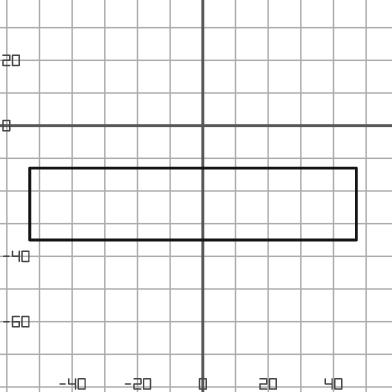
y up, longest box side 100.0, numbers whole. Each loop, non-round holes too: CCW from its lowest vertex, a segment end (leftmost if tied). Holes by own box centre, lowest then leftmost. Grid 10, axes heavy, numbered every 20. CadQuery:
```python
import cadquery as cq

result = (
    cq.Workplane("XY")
    .moveTo(-53.0, -35.0)
    .lineTo(47.0, -35.0)
    .lineTo(47.0, -13.0)
    .lineTo(-53.0, -13.0)
    .close()
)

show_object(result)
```